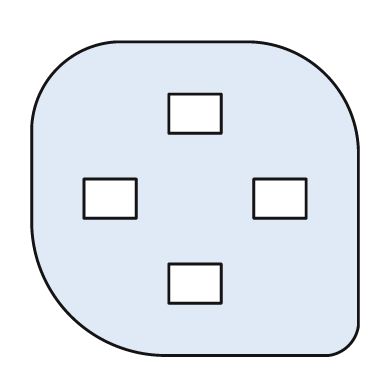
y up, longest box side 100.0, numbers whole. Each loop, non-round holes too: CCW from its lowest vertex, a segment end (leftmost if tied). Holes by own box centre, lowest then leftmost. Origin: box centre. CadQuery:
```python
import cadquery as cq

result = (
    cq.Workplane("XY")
    .moveTo(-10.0, -48.0)
    .lineTo(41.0, -48.0)
    .threePointArc((47.0, -45.0), (50.0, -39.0))
    .lineTo(50.0, 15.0)
    .threePointArc((40.0, 38.0), (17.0, 48.0))
    .lineTo(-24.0, 48.0)
    .threePointArc((-42.0, 40.0), (-50.0, 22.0))
    .lineTo(-50.0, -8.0)
    .threePointArc((-38.0, -36.0), (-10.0, -48.0))
    .close()
    .moveTo(-8.0, -32.0)
    .lineTo(8.0, -32.0)
    .lineTo(8.0, -20.0)
    .lineTo(-8.0, -20.0)
    .close()
    .moveTo(-34.0, -6.0)
    .lineTo(-18.0, -6.0)
    .lineTo(-18.0, 6.0)
    .lineTo(-34.0, 6.0)
    .close()
    .moveTo(18.0, -6.0)
    .lineTo(34.0, -6.0)
    .lineTo(34.0, 6.0)
    .lineTo(18.0, 6.0)
    .close()
    .moveTo(-8.0, 20.0)
    .lineTo(8.0, 20.0)
    .lineTo(8.0, 32.0)
    .lineTo(-8.0, 32.0)
    .close()
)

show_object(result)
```